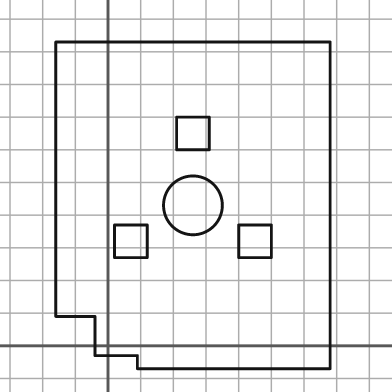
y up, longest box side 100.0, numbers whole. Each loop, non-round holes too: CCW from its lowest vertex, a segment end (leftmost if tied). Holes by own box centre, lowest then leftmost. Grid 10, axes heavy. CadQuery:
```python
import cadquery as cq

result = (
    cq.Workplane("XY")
    .moveTo(9.0, -7.0)
    .lineTo(68.0, -7.0)
    .lineTo(68.0, 93.0)
    .lineTo(-16.0, 93.0)
    .lineTo(-16.0, 9.0)
    .lineTo(-4.0, 9.0)
    .lineTo(-4.0, -3.0)
    .lineTo(9.0, -3.0)
    .close()
    .moveTo(2.0, 27.0)
    .lineTo(12.0, 27.0)
    .lineTo(12.0, 37.0)
    .lineTo(2.0, 37.0)
    .close()
    .moveTo(40.0, 27.0)
    .lineTo(50.0, 27.0)
    .lineTo(50.0, 37.0)
    .lineTo(40.0, 37.0)
    .close()
    .moveTo(26.0, 43.0)
    .circle(9.0)
    .moveTo(21.0, 60.0)
    .lineTo(31.0, 60.0)
    .lineTo(31.0, 70.0)
    .lineTo(21.0, 70.0)
    .close()
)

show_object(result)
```